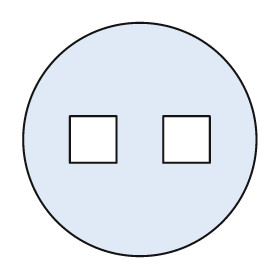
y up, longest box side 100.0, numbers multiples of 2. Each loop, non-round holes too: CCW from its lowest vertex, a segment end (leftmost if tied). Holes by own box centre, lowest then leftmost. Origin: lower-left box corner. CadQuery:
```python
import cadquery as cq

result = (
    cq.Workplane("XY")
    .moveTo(50.0, 50.0)
    .circle(50.0)
    .moveTo(20.0, 40.0)
    .lineTo(40.0, 40.0)
    .lineTo(40.0, 60.0)
    .lineTo(20.0, 60.0)
    .close()
    .moveTo(60.0, 40.0)
    .lineTo(80.0, 40.0)
    .lineTo(80.0, 60.0)
    .lineTo(60.0, 60.0)
    .close()
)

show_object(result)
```